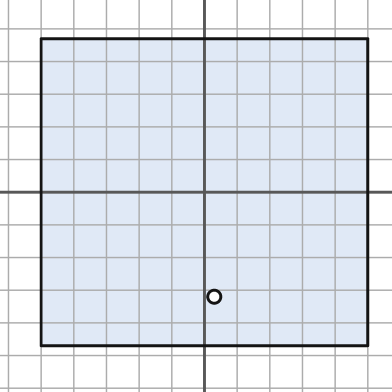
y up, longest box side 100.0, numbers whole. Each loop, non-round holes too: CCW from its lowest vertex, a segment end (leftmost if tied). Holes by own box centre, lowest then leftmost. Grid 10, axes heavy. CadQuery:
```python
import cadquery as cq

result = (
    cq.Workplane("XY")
    .moveTo(-50.0, -47.0)
    .lineTo(50.0, -47.0)
    .lineTo(50.0, 47.0)
    .lineTo(-50.0, 47.0)
    .close()
    .moveTo(3.0, -32.0)
    .circle(2.0)
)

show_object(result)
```